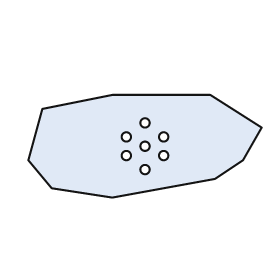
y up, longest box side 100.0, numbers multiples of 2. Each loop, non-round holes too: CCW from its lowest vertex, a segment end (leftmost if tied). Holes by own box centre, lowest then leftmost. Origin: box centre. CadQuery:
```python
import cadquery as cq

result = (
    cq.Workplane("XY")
    .moveTo(-14.0, -22.0)
    .lineTo(30.0, -14.0)
    .lineTo(42.0, -6.0)
    .lineTo(50.0, 8.0)
    .lineTo(28.0, 22.0)
    .lineTo(-14.0, 22.0)
    .lineTo(-44.0, 16.0)
    .lineTo(-50.0, -6.0)
    .lineTo(-40.0, -18.0)
    .close()
    .moveTo(0.0, -10.0)
    .circle(2.0)
    .moveTo(-8.0, -4.0)
    .circle(2.0)
    .moveTo(8.0, -4.0)
    .circle(2.0)
    .moveTo(0.0, 0.0)
    .circle(2.0)
    .moveTo(-8.0, 4.0)
    .circle(2.0)
    .moveTo(8.0, 4.0)
    .circle(2.0)
    .moveTo(0.0, 10.0)
    .circle(2.0)
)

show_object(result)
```